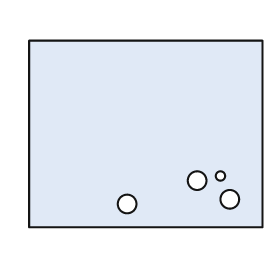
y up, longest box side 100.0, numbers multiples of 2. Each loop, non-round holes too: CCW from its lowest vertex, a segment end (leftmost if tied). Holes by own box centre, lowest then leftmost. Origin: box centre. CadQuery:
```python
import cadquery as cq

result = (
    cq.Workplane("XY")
    .moveTo(-50.0, -40.0)
    .lineTo(50.0, -40.0)
    .lineTo(50.0, 40.0)
    .lineTo(-50.0, 40.0)
    .close()
    .moveTo(-8.0, -30.0)
    .circle(4.0)
    .moveTo(36.0, -28.0)
    .circle(4.0)
    .moveTo(22.0, -20.0)
    .circle(4.0)
    .moveTo(32.0, -18.0)
    .circle(2.0)
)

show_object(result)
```